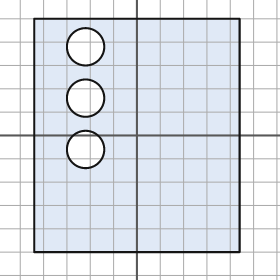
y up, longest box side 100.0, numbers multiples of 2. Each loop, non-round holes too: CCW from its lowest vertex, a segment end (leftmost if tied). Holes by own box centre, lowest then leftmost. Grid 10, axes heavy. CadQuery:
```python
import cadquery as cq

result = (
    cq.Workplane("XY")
    .moveTo(-44.0, -50.0)
    .lineTo(44.0, -50.0)
    .lineTo(44.0, 50.0)
    .lineTo(-44.0, 50.0)
    .close()
    .moveTo(-22.0, -6.0)
    .circle(8.0)
    .moveTo(-22.0, 16.0)
    .circle(8.0)
    .moveTo(-22.0, 38.0)
    .circle(8.0)
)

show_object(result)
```